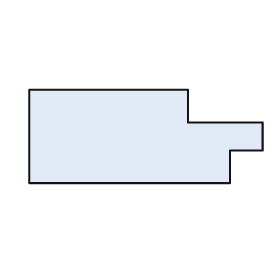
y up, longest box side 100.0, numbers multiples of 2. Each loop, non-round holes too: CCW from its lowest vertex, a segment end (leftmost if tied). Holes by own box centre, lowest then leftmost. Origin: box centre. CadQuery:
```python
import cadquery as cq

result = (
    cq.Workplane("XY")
    .moveTo(-50.0, -20.0)
    .lineTo(36.0, -20.0)
    .lineTo(36.0, -6.0)
    .lineTo(50.0, -6.0)
    .lineTo(50.0, 6.0)
    .lineTo(18.0, 6.0)
    .lineTo(18.0, 20.0)
    .lineTo(-50.0, 20.0)
    .close()
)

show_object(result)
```